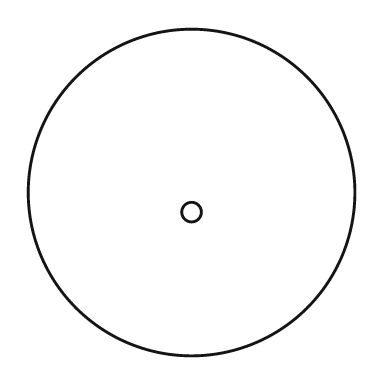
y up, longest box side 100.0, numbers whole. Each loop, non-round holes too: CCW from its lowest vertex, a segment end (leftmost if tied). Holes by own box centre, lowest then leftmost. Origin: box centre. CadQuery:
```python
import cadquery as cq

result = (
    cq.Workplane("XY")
    .moveTo(0.0, 0.0)
    .circle(50.0)
    .moveTo(0.0, -6.0)
    .circle(3.0)
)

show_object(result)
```